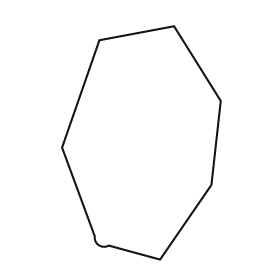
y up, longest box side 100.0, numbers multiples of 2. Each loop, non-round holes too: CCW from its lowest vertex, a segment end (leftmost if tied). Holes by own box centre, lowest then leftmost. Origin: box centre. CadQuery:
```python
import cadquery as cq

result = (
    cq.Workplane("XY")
    .moveTo(8.0, -50.0)
    .lineTo(30.0, -18.0)
    .lineTo(34.0, 18.0)
    .lineTo(14.0, 50.0)
    .lineTo(-18.0, 44.0)
    .lineTo(-34.0, -2.0)
    .lineTo(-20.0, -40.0)
    .threePointArc((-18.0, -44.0), (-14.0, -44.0))
    .close()
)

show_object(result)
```